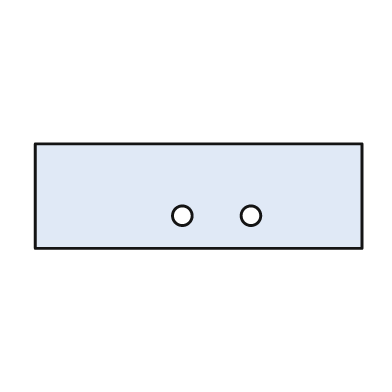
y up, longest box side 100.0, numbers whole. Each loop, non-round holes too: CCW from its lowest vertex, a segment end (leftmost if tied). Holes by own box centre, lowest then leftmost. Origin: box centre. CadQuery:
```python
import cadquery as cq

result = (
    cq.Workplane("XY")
    .moveTo(-50.0, -16.0)
    .lineTo(50.0, -16.0)
    .lineTo(50.0, 16.0)
    .lineTo(-50.0, 16.0)
    .close()
    .moveTo(-5.0, -6.0)
    .circle(3.0)
    .moveTo(16.0, -6.0)
    .circle(3.0)
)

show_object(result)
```